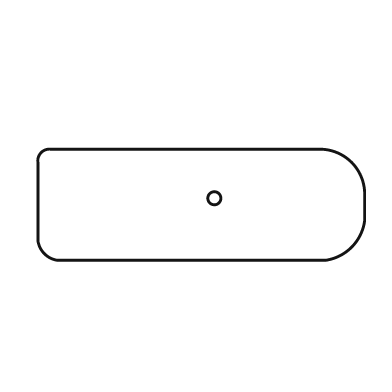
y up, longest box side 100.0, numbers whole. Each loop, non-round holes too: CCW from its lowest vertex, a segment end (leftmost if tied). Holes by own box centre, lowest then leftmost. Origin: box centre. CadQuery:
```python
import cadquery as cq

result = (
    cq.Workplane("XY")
    .moveTo(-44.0, -17.0)
    .lineTo(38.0, -17.0)
    .threePointArc((46.0, -13.0), (50.0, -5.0))
    .lineTo(50.0, 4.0)
    .threePointArc((46.0, 13.0), (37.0, 17.0))
    .lineTo(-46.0, 17.0)
    .threePointArc((-49.0, 16.0), (-50.0, 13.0))
    .lineTo(-50.0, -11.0)
    .threePointArc((-48.0, -15.0), (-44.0, -17.0))
    .close()
    .moveTo(4.0, 2.0)
    .circle(2.0)
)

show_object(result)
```